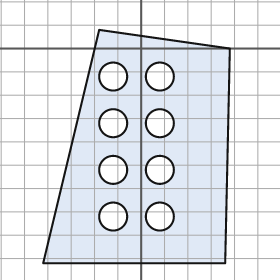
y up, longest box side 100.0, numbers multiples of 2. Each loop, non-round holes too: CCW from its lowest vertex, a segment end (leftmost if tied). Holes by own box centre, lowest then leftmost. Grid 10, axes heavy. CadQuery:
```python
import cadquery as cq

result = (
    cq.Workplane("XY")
    .moveTo(-42.0, -92.0)
    .lineTo(36.0, -92.0)
    .lineTo(38.0, 0.0)
    .lineTo(-18.0, 8.0)
    .close()
    .moveTo(-12.0, -72.0)
    .circle(6.0)
    .moveTo(8.0, -72.0)
    .circle(6.0)
    .moveTo(-12.0, -52.0)
    .circle(6.0)
    .moveTo(8.0, -52.0)
    .circle(6.0)
    .moveTo(-12.0, -32.0)
    .circle(6.0)
    .moveTo(8.0, -32.0)
    .circle(6.0)
    .moveTo(-12.0, -12.0)
    .circle(6.0)
    .moveTo(8.0, -12.0)
    .circle(6.0)
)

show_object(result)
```